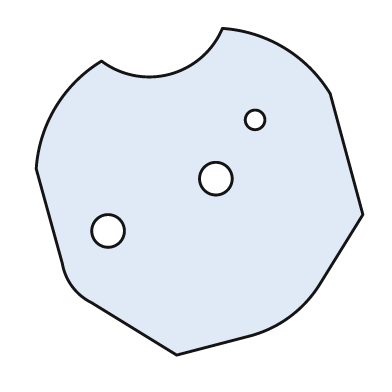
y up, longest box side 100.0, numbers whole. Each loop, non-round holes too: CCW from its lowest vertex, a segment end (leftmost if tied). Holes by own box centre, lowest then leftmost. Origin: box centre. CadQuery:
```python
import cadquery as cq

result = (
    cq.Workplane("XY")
    .moveTo(-7.0, -50.0)
    .lineTo(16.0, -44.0)
    .threePointArc((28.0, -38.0), (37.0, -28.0))
    .lineTo(50.0, -7.0)
    .lineTo(40.0, 30.0)
    .threePointArc((26.0, 44.0), (7.0, 50.0))
    .threePointArc((-9.0, 36.0), (-30.0, 40.0))
    .threePointArc((-44.0, 26.0), (-50.0, 7.0))
    .lineTo(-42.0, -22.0)
    .threePointArc((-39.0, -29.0), (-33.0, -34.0))
    .close()
    .moveTo(-28.0, -12.0)
    .circle(5.0)
    .moveTo(5.0, 4.0)
    .circle(5.0)
    .moveTo(17.0, 22.0)
    .circle(3.0)
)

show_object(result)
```